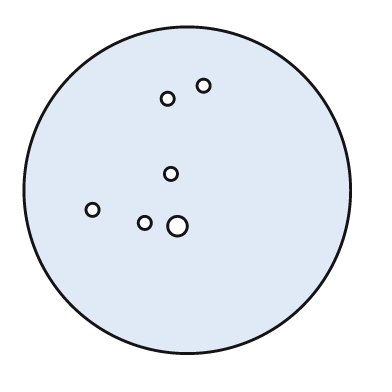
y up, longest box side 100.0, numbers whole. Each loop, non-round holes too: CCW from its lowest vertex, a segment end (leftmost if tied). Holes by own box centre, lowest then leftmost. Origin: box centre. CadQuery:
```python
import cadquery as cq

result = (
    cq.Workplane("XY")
    .moveTo(0.0, 0.0)
    .circle(50.0)
    .moveTo(-3.0, -11.0)
    .circle(3.0)
    .moveTo(-13.0, -10.0)
    .circle(2.0)
    .moveTo(-29.0, -6.0)
    .circle(2.0)
    .moveTo(-5.0, 5.0)
    .circle(2.0)
    .moveTo(-6.0, 28.0)
    .circle(2.0)
    .moveTo(5.0, 32.0)
    .circle(2.0)
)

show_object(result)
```